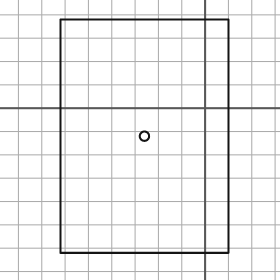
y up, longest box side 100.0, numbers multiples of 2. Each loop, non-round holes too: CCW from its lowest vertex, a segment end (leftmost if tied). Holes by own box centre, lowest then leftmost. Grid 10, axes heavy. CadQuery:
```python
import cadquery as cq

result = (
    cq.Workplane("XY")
    .moveTo(-62.0, -62.0)
    .lineTo(10.0, -62.0)
    .lineTo(10.0, 38.0)
    .lineTo(-62.0, 38.0)
    .close()
    .moveTo(-26.0, -12.0)
    .circle(2.0)
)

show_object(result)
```